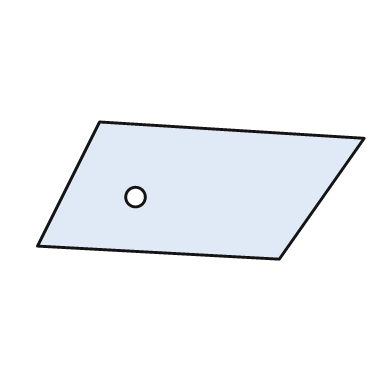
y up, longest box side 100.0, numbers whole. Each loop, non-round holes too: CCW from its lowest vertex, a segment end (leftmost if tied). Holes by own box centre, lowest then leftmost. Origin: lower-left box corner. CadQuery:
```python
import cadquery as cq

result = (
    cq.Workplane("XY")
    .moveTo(74.0, 0.0)
    .lineTo(100.0, 37.0)
    .lineTo(19.0, 42.0)
    .lineTo(0.0, 4.0)
    .close()
    .moveTo(30.0, 19.0)
    .circle(3.0)
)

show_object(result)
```